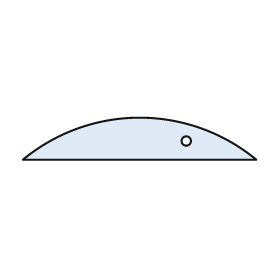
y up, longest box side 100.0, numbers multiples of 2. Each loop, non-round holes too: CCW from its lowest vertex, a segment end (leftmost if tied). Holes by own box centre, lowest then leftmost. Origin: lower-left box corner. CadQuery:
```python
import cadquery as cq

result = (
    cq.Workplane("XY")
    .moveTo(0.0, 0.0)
    .lineTo(100.0, 0.0)
    .threePointArc((50.0, 18.0), (0.0, 0.0))
    .close()
    .moveTo(70.0, 8.0)
    .circle(2.0)
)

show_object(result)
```